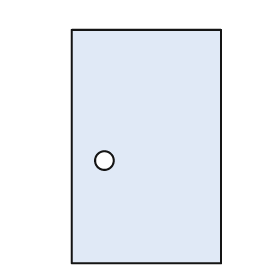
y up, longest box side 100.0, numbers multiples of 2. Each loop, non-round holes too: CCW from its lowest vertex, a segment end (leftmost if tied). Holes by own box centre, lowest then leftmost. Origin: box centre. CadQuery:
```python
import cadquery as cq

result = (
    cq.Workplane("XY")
    .moveTo(-32.0, -50.0)
    .lineTo(32.0, -50.0)
    .lineTo(32.0, 50.0)
    .lineTo(-32.0, 50.0)
    .close()
    .moveTo(-18.0, -6.0)
    .circle(4.0)
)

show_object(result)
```